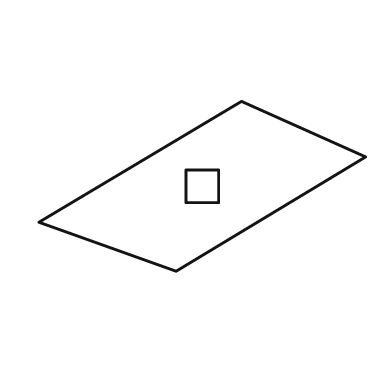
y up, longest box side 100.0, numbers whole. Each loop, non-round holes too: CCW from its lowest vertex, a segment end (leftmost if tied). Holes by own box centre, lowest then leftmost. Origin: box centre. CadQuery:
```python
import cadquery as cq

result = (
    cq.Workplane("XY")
    .moveTo(-8.0, -26.0)
    .lineTo(50.0, 9.0)
    .lineTo(12.0, 26.0)
    .lineTo(-50.0, -11.0)
    .close()
    .moveTo(-5.0, -5.0)
    .lineTo(5.0, -5.0)
    .lineTo(5.0, 5.0)
    .lineTo(-5.0, 5.0)
    .close()
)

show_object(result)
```